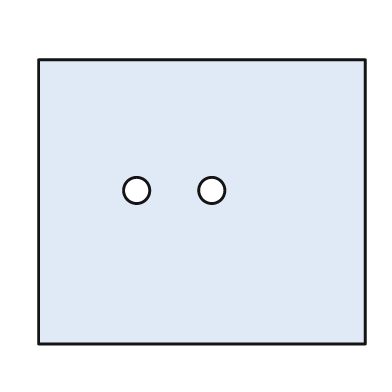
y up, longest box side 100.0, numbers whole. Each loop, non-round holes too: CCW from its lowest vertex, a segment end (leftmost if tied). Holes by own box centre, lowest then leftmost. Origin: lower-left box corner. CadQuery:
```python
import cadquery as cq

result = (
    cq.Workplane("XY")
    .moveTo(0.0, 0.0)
    .lineTo(100.0, 0.0)
    .lineTo(100.0, 87.0)
    .lineTo(0.0, 87.0)
    .close()
    .moveTo(30.0, 47.0)
    .circle(4.0)
    .moveTo(53.0, 47.0)
    .circle(4.0)
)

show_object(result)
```